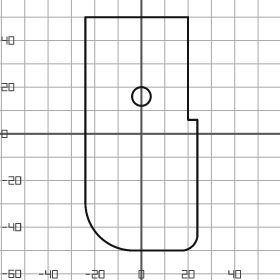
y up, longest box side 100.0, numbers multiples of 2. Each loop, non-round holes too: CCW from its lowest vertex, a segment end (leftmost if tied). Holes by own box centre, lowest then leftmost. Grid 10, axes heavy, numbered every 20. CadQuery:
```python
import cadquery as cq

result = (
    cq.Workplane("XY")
    .moveTo(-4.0, -50.0)
    .lineTo(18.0, -50.0)
    .threePointArc((22.0, -48.0), (24.0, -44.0))
    .lineTo(24.0, 6.0)
    .lineTo(20.0, 6.0)
    .lineTo(20.0, 50.0)
    .lineTo(-24.0, 50.0)
    .lineTo(-24.0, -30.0)
    .threePointArc((-18.0, -44.0), (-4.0, -50.0))
    .close()
    .moveTo(0.0, 16.0)
    .circle(4.0)
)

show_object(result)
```